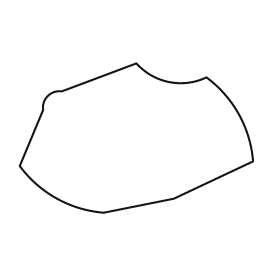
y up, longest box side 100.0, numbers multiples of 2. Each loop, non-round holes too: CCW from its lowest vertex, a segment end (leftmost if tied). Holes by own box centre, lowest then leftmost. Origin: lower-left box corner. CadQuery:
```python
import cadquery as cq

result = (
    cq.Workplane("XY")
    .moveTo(36.0, 0.0)
    .lineTo(66.0, 6.0)
    .lineTo(100.0, 22.0)
    .threePointArc((94.0, 42.0), (80.0, 58.0))
    .threePointArc((64.0, 56.0), (50.0, 64.0))
    .lineTo(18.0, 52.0)
    .threePointArc((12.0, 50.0), (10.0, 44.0))
    .lineTo(0.0, 20.0)
    .threePointArc((16.0, 6.0), (36.0, 0.0))
    .close()
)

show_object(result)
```